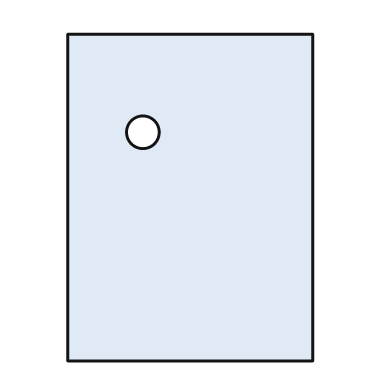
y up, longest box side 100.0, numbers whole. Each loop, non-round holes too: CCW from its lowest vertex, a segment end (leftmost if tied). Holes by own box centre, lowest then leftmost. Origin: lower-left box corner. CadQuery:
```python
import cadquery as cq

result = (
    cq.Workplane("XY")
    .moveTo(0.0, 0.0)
    .lineTo(75.0, 0.0)
    .lineTo(75.0, 100.0)
    .lineTo(0.0, 100.0)
    .close()
    .moveTo(23.0, 70.0)
    .circle(5.0)
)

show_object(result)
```